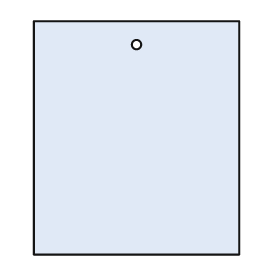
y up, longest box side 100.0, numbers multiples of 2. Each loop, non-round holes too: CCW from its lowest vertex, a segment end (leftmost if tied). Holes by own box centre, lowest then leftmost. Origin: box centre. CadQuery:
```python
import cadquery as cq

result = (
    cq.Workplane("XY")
    .moveTo(-44.0, -50.0)
    .lineTo(44.0, -50.0)
    .lineTo(44.0, 50.0)
    .lineTo(-44.0, 50.0)
    .close()
    .moveTo(0.0, 40.0)
    .circle(2.0)
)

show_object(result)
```